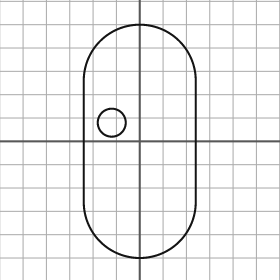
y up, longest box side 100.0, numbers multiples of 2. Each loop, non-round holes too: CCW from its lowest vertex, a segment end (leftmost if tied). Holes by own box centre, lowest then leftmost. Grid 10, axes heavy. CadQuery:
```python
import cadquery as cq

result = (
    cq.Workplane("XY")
    .moveTo(-24.0, -26.0)
    .threePointArc((0.0, -50.0), (24.0, -26.0))
    .lineTo(24.0, 26.0)
    .threePointArc((0.0, 50.0), (-24.0, 26.0))
    .close()
    .moveTo(-12.0, 8.0)
    .circle(6.0)
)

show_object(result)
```